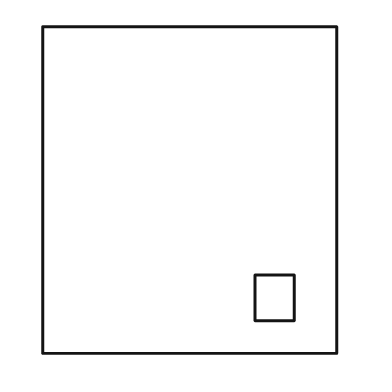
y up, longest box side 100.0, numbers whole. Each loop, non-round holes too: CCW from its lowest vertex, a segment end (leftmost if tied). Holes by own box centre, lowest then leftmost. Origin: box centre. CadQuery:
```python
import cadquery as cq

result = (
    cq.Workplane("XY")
    .moveTo(-45.0, -50.0)
    .lineTo(45.0, -50.0)
    .lineTo(45.0, 50.0)
    .lineTo(-45.0, 50.0)
    .close()
    .moveTo(20.0, -40.0)
    .lineTo(32.0, -40.0)
    .lineTo(32.0, -26.0)
    .lineTo(20.0, -26.0)
    .close()
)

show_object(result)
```